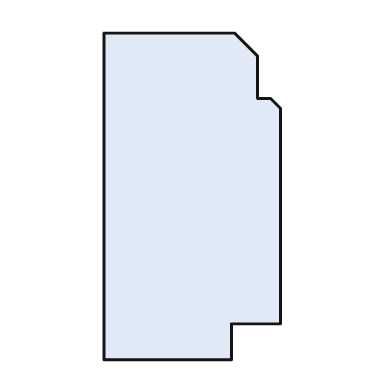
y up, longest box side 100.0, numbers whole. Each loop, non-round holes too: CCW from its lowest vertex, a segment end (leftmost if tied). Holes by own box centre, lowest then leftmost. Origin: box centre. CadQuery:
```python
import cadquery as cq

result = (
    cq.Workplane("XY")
    .moveTo(-27.0, -50.0)
    .lineTo(12.0, -50.0)
    .lineTo(12.0, -39.0)
    .lineTo(27.0, -39.0)
    .lineTo(27.0, 27.0)
    .lineTo(24.0, 30.0)
    .lineTo(20.0, 30.0)
    .lineTo(20.0, 43.0)
    .lineTo(13.0, 50.0)
    .lineTo(-27.0, 50.0)
    .close()
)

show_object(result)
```